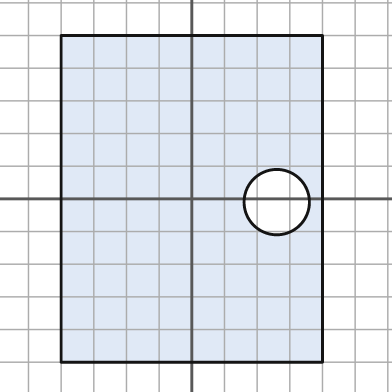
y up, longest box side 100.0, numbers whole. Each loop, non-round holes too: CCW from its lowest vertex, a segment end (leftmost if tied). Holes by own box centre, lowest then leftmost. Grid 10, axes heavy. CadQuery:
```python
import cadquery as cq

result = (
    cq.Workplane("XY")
    .moveTo(-40.0, -50.0)
    .lineTo(40.0, -50.0)
    .lineTo(40.0, 50.0)
    .lineTo(-40.0, 50.0)
    .close()
    .moveTo(26.0, -1.0)
    .circle(10.0)
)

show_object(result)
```